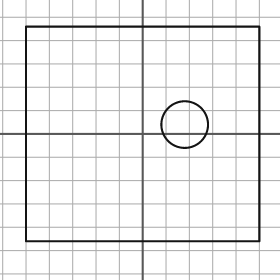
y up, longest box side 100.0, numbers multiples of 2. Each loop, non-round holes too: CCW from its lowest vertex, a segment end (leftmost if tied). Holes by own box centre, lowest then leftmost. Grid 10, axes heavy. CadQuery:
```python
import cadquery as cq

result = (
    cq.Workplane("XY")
    .moveTo(-50.0, -46.0)
    .lineTo(50.0, -46.0)
    .lineTo(50.0, 46.0)
    .lineTo(-50.0, 46.0)
    .close()
    .moveTo(18.0, 4.0)
    .circle(10.0)
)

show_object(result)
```